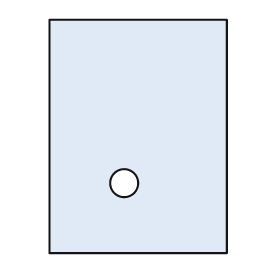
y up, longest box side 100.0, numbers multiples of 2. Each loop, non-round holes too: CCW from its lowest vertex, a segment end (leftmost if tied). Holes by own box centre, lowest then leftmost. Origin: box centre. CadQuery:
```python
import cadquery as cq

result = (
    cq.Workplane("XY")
    .moveTo(-38.0, -50.0)
    .lineTo(38.0, -50.0)
    .lineTo(38.0, 50.0)
    .lineTo(-38.0, 50.0)
    .close()
    .moveTo(-6.0, -20.0)
    .circle(6.0)
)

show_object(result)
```